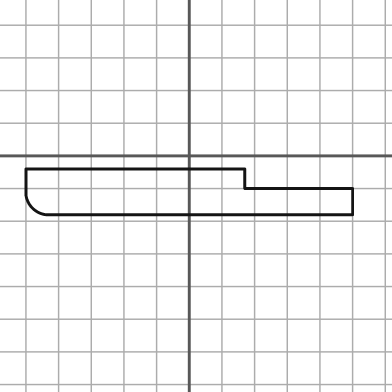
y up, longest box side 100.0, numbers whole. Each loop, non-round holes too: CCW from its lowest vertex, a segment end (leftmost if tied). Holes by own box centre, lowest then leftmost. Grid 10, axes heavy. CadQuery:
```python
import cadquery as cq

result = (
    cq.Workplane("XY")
    .moveTo(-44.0, -18.0)
    .lineTo(50.0, -18.0)
    .lineTo(50.0, -10.0)
    .lineTo(17.0, -10.0)
    .lineTo(17.0, -4.0)
    .lineTo(-50.0, -4.0)
    .lineTo(-50.0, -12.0)
    .threePointArc((-48.0, -16.0), (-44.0, -18.0))
    .close()
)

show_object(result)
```